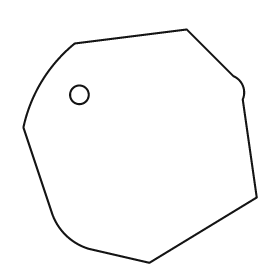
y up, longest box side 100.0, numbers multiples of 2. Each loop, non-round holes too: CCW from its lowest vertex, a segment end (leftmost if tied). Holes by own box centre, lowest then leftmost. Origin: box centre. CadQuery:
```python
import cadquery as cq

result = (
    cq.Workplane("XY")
    .moveTo(4.0, -50.0)
    .lineTo(50.0, -22.0)
    .lineTo(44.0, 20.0)
    .threePointArc((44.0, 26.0), (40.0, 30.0))
    .lineTo(20.0, 50.0)
    .lineTo(-28.0, 44.0)
    .threePointArc((-42.0, 28.0), (-50.0, 8.0))
    .lineTo(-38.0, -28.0)
    .threePointArc((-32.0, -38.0), (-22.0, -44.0))
    .close()
    .moveTo(-26.0, 22.0)
    .circle(4.0)
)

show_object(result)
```